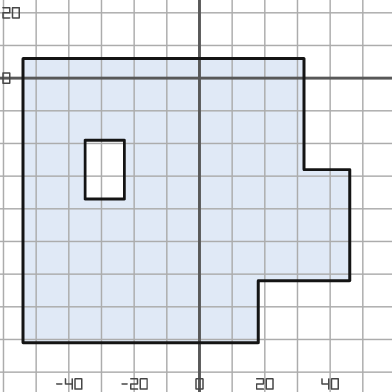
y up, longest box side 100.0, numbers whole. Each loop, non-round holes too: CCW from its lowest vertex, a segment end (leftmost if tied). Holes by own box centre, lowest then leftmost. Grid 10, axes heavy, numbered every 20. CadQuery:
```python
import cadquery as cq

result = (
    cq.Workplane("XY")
    .moveTo(-54.0, -81.0)
    .lineTo(18.0, -81.0)
    .lineTo(18.0, -62.0)
    .lineTo(46.0, -62.0)
    .lineTo(46.0, -28.0)
    .lineTo(32.0, -28.0)
    .lineTo(32.0, 6.0)
    .lineTo(-54.0, 6.0)
    .close()
    .moveTo(-35.0, -37.0)
    .lineTo(-23.0, -37.0)
    .lineTo(-23.0, -19.0)
    .lineTo(-35.0, -19.0)
    .close()
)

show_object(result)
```